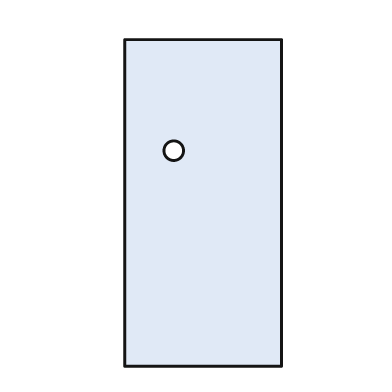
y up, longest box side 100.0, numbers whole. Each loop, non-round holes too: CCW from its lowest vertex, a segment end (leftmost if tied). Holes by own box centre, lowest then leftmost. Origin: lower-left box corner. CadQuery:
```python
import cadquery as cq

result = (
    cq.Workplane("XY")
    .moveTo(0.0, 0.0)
    .lineTo(48.0, 0.0)
    .lineTo(48.0, 100.0)
    .lineTo(0.0, 100.0)
    .close()
    .moveTo(15.0, 66.0)
    .circle(3.0)
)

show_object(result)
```